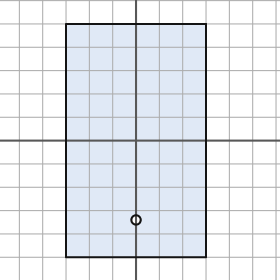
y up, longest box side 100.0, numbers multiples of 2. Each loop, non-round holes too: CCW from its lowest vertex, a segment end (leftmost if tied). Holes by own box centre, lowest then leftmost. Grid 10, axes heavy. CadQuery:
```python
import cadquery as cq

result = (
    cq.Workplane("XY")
    .moveTo(-30.0, -50.0)
    .lineTo(30.0, -50.0)
    .lineTo(30.0, 50.0)
    .lineTo(-30.0, 50.0)
    .close()
    .moveTo(0.0, -34.0)
    .circle(2.0)
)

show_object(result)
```